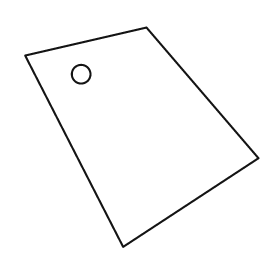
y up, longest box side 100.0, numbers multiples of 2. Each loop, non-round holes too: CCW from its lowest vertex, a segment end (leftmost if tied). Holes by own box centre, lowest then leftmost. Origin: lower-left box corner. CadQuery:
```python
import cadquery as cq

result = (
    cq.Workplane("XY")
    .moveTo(42.0, 0.0)
    .lineTo(100.0, 38.0)
    .lineTo(52.0, 94.0)
    .lineTo(0.0, 82.0)
    .close()
    .moveTo(24.0, 74.0)
    .circle(4.0)
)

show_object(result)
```